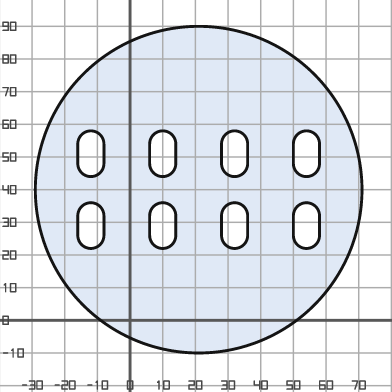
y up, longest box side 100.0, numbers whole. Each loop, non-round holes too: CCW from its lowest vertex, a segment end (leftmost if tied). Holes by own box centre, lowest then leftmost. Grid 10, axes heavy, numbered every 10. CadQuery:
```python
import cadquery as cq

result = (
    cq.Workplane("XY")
    .moveTo(21.0, 40.0)
    .circle(50.0)
    .moveTo(-16.0, 26.0)
    .threePointArc((-12.0, 22.0), (-8.0, 26.0))
    .lineTo(-8.0, 32.0)
    .threePointArc((-12.0, 36.0), (-16.0, 32.0))
    .close()
    .moveTo(6.0, 26.0)
    .threePointArc((10.0, 22.0), (14.0, 26.0))
    .lineTo(14.0, 32.0)
    .threePointArc((10.0, 36.0), (6.0, 32.0))
    .close()
    .moveTo(28.0, 26.0)
    .threePointArc((32.0, 22.0), (36.0, 26.0))
    .lineTo(36.0, 32.0)
    .threePointArc((32.0, 36.0), (28.0, 32.0))
    .close()
    .moveTo(50.0, 26.0)
    .threePointArc((54.0, 22.0), (58.0, 26.0))
    .lineTo(58.0, 32.0)
    .threePointArc((54.0, 36.0), (50.0, 32.0))
    .close()
    .moveTo(-16.0, 48.0)
    .threePointArc((-12.0, 44.0), (-8.0, 48.0))
    .lineTo(-8.0, 54.0)
    .threePointArc((-12.0, 58.0), (-16.0, 54.0))
    .close()
    .moveTo(6.0, 48.0)
    .threePointArc((10.0, 44.0), (14.0, 48.0))
    .lineTo(14.0, 54.0)
    .threePointArc((10.0, 58.0), (6.0, 54.0))
    .close()
    .moveTo(28.0, 48.0)
    .threePointArc((32.0, 44.0), (36.0, 48.0))
    .lineTo(36.0, 54.0)
    .threePointArc((32.0, 58.0), (28.0, 54.0))
    .close()
    .moveTo(50.0, 48.0)
    .threePointArc((54.0, 44.0), (58.0, 48.0))
    .lineTo(58.0, 54.0)
    .threePointArc((54.0, 58.0), (50.0, 54.0))
    .close()
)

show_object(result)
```